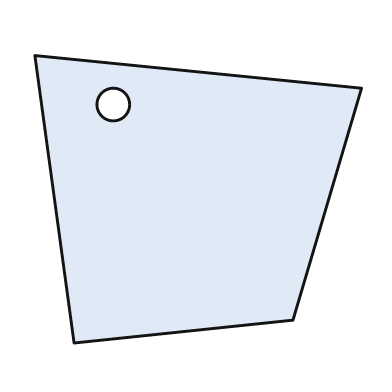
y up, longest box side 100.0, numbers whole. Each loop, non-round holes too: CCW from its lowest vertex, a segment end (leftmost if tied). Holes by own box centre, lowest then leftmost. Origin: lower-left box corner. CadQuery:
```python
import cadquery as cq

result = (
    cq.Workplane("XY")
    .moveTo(12.0, 0.0)
    .lineTo(79.0, 7.0)
    .lineTo(100.0, 78.0)
    .lineTo(0.0, 88.0)
    .close()
    .moveTo(24.0, 73.0)
    .circle(5.0)
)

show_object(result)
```